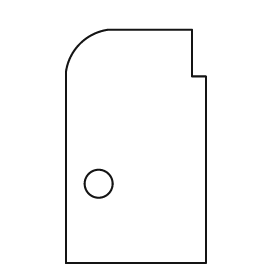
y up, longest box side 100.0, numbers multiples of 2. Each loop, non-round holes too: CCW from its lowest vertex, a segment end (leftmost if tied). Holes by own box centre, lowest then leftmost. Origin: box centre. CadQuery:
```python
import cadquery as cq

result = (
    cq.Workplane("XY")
    .moveTo(-30.0, -50.0)
    .lineTo(30.0, -50.0)
    .lineTo(30.0, 30.0)
    .lineTo(24.0, 30.0)
    .lineTo(24.0, 50.0)
    .lineTo(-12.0, 50.0)
    .threePointArc((-24.0, 44.0), (-30.0, 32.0))
    .close()
    .moveTo(-16.0, -16.0)
    .circle(6.0)
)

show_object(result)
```